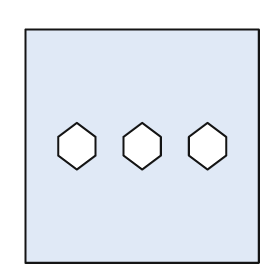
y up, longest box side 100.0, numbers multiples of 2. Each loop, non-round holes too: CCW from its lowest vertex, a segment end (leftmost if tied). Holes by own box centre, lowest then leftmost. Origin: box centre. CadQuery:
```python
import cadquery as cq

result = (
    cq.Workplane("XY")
    .moveTo(-50.0, -50.0)
    .lineTo(50.0, -50.0)
    .lineTo(50.0, 50.0)
    .lineTo(-50.0, 50.0)
    .close()
    .moveTo(-28.0, -10.0)
    .lineTo(-20.0, -4.0)
    .lineTo(-20.0, 4.0)
    .lineTo(-28.0, 10.0)
    .lineTo(-36.0, 4.0)
    .lineTo(-36.0, -4.0)
    .close()
    .moveTo(0.0, -10.0)
    .lineTo(8.0, -4.0)
    .lineTo(8.0, 4.0)
    .lineTo(0.0, 10.0)
    .lineTo(-8.0, 4.0)
    .lineTo(-8.0, -4.0)
    .close()
    .moveTo(28.0, -10.0)
    .lineTo(36.0, -4.0)
    .lineTo(36.0, 4.0)
    .lineTo(28.0, 10.0)
    .lineTo(20.0, 4.0)
    .lineTo(20.0, -4.0)
    .close()
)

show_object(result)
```